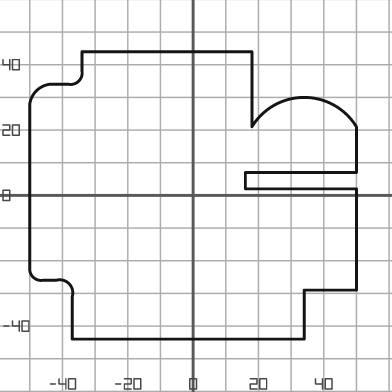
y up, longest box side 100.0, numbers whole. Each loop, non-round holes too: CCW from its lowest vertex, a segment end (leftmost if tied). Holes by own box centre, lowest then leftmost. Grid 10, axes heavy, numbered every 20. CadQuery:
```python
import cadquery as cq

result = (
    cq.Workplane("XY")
    .moveTo(-37.0, -44.0)
    .lineTo(34.0, -44.0)
    .lineTo(34.0, -29.0)
    .lineTo(50.0, -29.0)
    .lineTo(50.0, 2.0)
    .lineTo(16.0, 2.0)
    .lineTo(16.0, 7.0)
    .lineTo(50.0, 7.0)
    .lineTo(50.0, 21.0)
    .threePointArc((34.0, 30.0), (18.0, 21.0))
    .lineTo(18.0, 44.0)
    .lineTo(-34.0, 44.0)
    .lineTo(-34.0, 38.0)
    .threePointArc((-35.0, 35.0), (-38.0, 34.0))
    .lineTo(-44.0, 34.0)
    .threePointArc((-48.0, 32.0), (-50.0, 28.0))
    .lineTo(-50.0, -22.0)
    .threePointArc((-49.0, -25.0), (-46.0, -26.0))
    .lineTo(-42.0, -26.0)
    .threePointArc((-38.0, -27.0), (-37.0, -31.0))
    .close()
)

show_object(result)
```